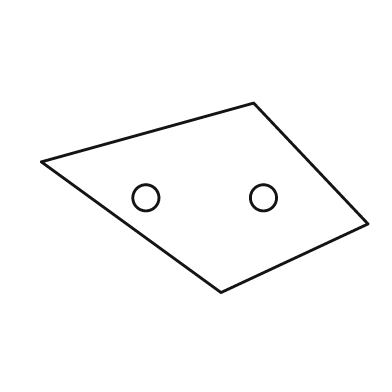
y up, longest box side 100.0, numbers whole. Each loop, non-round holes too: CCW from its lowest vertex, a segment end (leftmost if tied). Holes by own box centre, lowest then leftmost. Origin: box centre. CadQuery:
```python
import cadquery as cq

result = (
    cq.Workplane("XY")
    .moveTo(5.0, -29.0)
    .lineTo(50.0, -8.0)
    .lineTo(15.0, 29.0)
    .lineTo(-50.0, 11.0)
    .close()
    .moveTo(-18.0, 0.0)
    .circle(4.0)
    .moveTo(18.0, 0.0)
    .circle(4.0)
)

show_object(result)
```